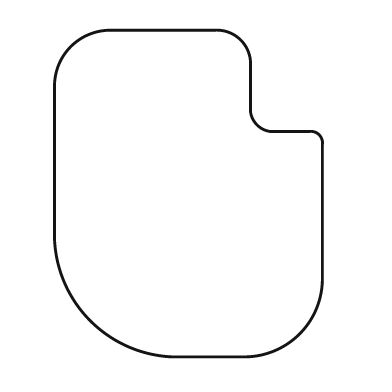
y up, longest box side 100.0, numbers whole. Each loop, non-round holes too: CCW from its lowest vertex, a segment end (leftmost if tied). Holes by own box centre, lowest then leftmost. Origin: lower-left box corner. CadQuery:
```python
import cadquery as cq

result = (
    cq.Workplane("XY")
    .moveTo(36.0, 0.0)
    .lineTo(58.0, 0.0)
    .threePointArc((75.0, 7.0), (82.0, 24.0))
    .lineTo(82.0, 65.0)
    .threePointArc((81.0, 68.0), (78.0, 69.0))
    .lineTo(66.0, 69.0)
    .threePointArc((62.0, 71.0), (60.0, 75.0))
    .lineTo(60.0, 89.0)
    .threePointArc((57.0, 97.0), (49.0, 100.0))
    .lineTo(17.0, 100.0)
    .threePointArc((5.0, 95.0), (0.0, 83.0))
    .lineTo(0.0, 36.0)
    .threePointArc((11.0, 11.0), (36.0, 0.0))
    .close()
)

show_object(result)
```